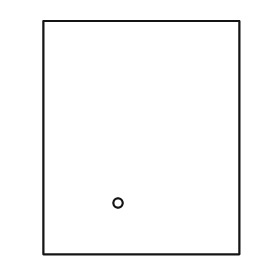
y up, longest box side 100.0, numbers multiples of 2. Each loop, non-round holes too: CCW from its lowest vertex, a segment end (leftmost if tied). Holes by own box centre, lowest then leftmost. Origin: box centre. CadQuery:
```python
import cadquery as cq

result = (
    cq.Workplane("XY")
    .moveTo(-42.0, -50.0)
    .lineTo(42.0, -50.0)
    .lineTo(42.0, 50.0)
    .lineTo(-42.0, 50.0)
    .close()
    .moveTo(-10.0, -28.0)
    .circle(2.0)
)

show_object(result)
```